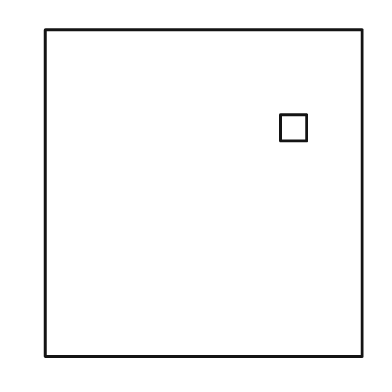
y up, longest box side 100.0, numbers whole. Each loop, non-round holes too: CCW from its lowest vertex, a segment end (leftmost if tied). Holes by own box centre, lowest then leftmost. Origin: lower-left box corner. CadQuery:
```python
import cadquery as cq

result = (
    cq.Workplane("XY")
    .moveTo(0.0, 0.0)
    .lineTo(97.0, 0.0)
    .lineTo(97.0, 100.0)
    .lineTo(0.0, 100.0)
    .close()
    .moveTo(72.0, 66.0)
    .lineTo(80.0, 66.0)
    .lineTo(80.0, 74.0)
    .lineTo(72.0, 74.0)
    .close()
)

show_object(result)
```